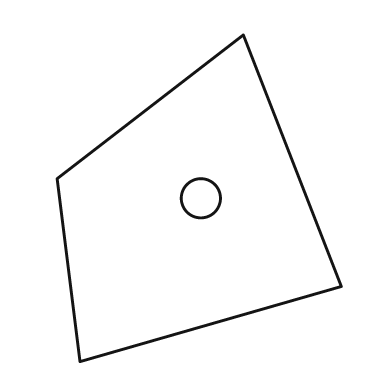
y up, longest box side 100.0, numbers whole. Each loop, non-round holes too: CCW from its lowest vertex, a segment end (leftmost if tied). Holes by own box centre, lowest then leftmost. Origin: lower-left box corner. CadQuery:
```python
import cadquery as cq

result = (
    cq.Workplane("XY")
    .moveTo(7.0, 0.0)
    .lineTo(87.0, 23.0)
    .lineTo(57.0, 100.0)
    .lineTo(0.0, 56.0)
    .close()
    .moveTo(44.0, 50.0)
    .circle(6.0)
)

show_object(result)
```